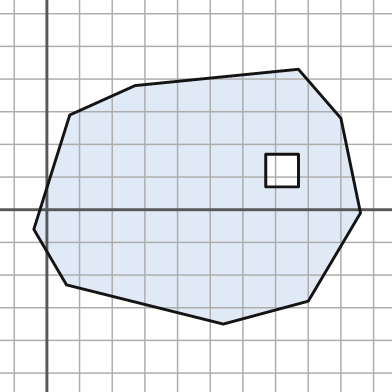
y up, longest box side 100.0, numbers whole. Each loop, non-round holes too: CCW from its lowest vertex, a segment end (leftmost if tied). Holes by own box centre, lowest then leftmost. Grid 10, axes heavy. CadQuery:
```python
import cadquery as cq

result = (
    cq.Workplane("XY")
    .moveTo(54.0, -35.0)
    .lineTo(80.0, -28.0)
    .lineTo(96.0, -1.0)
    .lineTo(90.0, 28.0)
    .lineTo(77.0, 43.0)
    .lineTo(27.0, 38.0)
    .lineTo(7.0, 29.0)
    .lineTo(-4.0, -6.0)
    .lineTo(6.0, -23.0)
    .close()
    .moveTo(67.0, 7.0)
    .lineTo(77.0, 7.0)
    .lineTo(77.0, 17.0)
    .lineTo(67.0, 17.0)
    .close()
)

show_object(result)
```